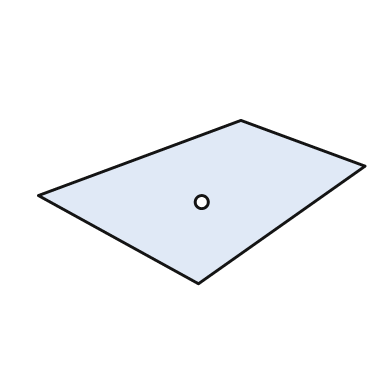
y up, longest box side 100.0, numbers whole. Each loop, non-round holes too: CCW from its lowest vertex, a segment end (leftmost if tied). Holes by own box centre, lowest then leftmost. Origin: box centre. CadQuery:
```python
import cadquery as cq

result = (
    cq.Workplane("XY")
    .moveTo(-1.0, -25.0)
    .lineTo(50.0, 11.0)
    .lineTo(12.0, 25.0)
    .lineTo(-50.0, 2.0)
    .close()
    .moveTo(0.0, 0.0)
    .circle(2.0)
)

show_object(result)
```